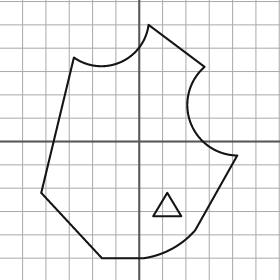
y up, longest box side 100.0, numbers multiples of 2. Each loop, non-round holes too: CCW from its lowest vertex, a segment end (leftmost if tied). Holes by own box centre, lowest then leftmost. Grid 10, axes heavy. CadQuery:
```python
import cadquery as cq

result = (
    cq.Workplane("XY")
    .moveTo(-16.0, -50.0)
    .lineTo(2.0, -50.0)
    .threePointArc((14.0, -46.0), (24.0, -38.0))
    .lineTo(42.0, -6.0)
    .threePointArc((22.0, 8.0), (28.0, 32.0))
    .lineTo(4.0, 50.0)
    .threePointArc((-8.0, 34.0), (-28.0, 36.0))
    .lineTo(-42.0, -22.0)
    .close()
    .moveTo(6.0, -32.0)
    .lineTo(18.0, -32.0)
    .lineTo(12.0, -22.0)
    .close()
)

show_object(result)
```